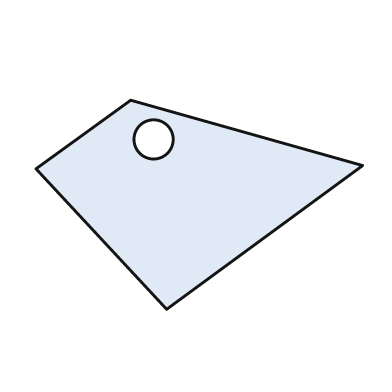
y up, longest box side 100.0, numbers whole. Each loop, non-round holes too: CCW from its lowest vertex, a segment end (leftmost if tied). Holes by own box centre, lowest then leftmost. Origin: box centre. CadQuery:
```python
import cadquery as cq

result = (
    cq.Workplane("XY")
    .moveTo(-10.0, -32.0)
    .lineTo(50.0, 12.0)
    .lineTo(-21.0, 32.0)
    .lineTo(-50.0, 11.0)
    .close()
    .moveTo(-14.0, 20.0)
    .circle(6.0)
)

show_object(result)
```